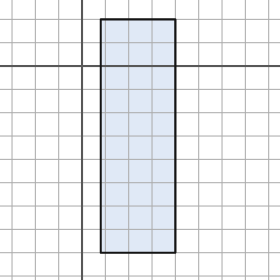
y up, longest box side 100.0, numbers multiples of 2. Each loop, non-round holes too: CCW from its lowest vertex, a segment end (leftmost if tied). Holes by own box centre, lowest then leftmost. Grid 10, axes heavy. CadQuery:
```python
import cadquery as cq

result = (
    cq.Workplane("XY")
    .moveTo(8.0, -80.0)
    .lineTo(40.0, -80.0)
    .lineTo(40.0, 20.0)
    .lineTo(8.0, 20.0)
    .close()
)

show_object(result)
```